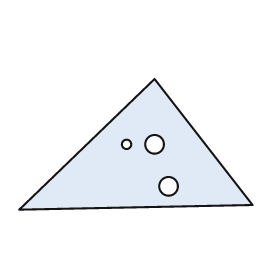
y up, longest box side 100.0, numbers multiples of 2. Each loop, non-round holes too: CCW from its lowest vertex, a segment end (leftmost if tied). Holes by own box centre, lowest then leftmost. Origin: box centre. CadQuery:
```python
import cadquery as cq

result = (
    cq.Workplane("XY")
    .moveTo(-50.0, -28.0)
    .lineTo(50.0, -26.0)
    .lineTo(8.0, 28.0)
    .close()
    .moveTo(14.0, -18.0)
    .circle(4.0)
    .moveTo(-4.0, 0.0)
    .circle(2.0)
    .moveTo(8.0, 0.0)
    .circle(4.0)
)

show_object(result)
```